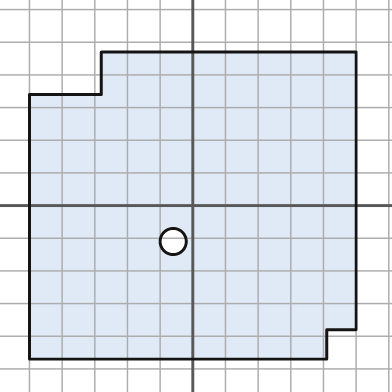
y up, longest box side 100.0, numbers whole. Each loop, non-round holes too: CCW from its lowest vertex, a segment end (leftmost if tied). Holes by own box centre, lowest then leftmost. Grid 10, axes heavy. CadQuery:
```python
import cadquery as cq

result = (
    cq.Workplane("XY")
    .moveTo(-50.0, -47.0)
    .lineTo(41.0, -47.0)
    .lineTo(41.0, -38.0)
    .lineTo(50.0, -38.0)
    .lineTo(50.0, 47.0)
    .lineTo(-28.0, 47.0)
    .lineTo(-28.0, 34.0)
    .lineTo(-50.0, 34.0)
    .close()
    .moveTo(-6.0, -11.0)
    .circle(4.0)
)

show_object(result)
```